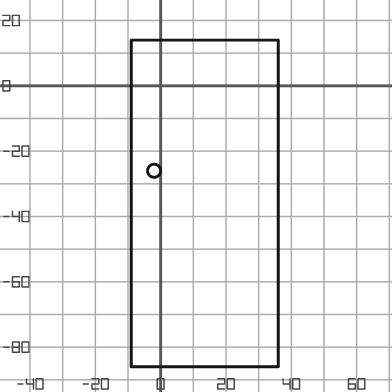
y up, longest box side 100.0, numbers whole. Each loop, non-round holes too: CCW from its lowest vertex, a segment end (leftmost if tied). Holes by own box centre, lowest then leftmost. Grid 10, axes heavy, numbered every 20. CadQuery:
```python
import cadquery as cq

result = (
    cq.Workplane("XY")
    .moveTo(-9.0, -86.0)
    .lineTo(36.0, -86.0)
    .lineTo(36.0, 14.0)
    .lineTo(-9.0, 14.0)
    .close()
    .moveTo(-2.0, -26.0)
    .circle(2.0)
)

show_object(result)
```